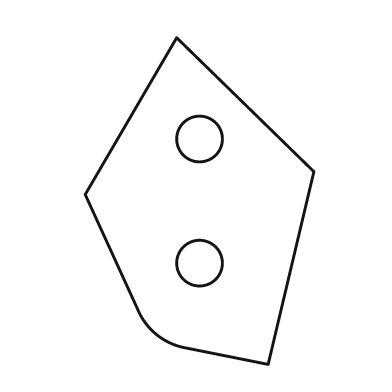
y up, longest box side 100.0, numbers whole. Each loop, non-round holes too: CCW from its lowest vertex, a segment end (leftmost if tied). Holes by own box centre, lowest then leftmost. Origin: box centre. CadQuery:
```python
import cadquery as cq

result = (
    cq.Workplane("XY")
    .moveTo(21.0, -50.0)
    .lineTo(35.0, 9.0)
    .lineTo(-7.0, 50.0)
    .lineTo(-35.0, 2.0)
    .lineTo(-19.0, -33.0)
    .threePointArc((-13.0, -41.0), (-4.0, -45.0))
    .close()
    .moveTo(0.0, -19.0)
    .circle(7.0)
    .moveTo(0.0, 19.0)
    .circle(7.0)
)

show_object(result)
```